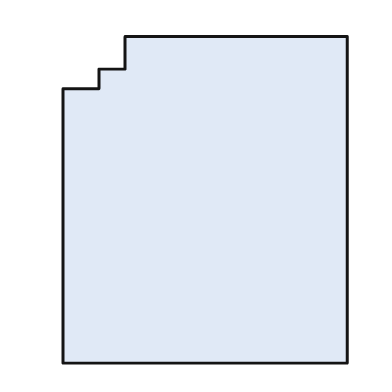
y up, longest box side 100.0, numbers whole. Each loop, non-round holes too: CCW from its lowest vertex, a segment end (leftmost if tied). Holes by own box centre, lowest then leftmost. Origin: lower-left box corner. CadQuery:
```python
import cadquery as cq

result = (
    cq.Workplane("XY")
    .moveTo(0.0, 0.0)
    .lineTo(87.0, 0.0)
    .lineTo(87.0, 100.0)
    .lineTo(19.0, 100.0)
    .lineTo(19.0, 90.0)
    .lineTo(11.0, 90.0)
    .lineTo(11.0, 84.0)
    .lineTo(0.0, 84.0)
    .close()
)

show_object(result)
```